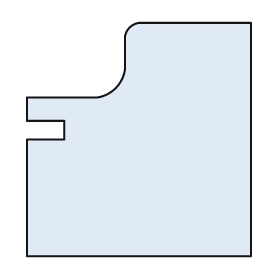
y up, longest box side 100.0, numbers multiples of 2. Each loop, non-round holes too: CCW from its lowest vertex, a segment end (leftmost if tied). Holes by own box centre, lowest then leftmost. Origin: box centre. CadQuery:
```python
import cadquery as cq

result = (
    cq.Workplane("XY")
    .moveTo(-48.0, -50.0)
    .lineTo(48.0, -50.0)
    .lineTo(48.0, 50.0)
    .lineTo(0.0, 50.0)
    .threePointArc((-4.0, 48.0), (-6.0, 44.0))
    .lineTo(-6.0, 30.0)
    .threePointArc((-10.0, 22.0), (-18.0, 18.0))
    .lineTo(-48.0, 18.0)
    .lineTo(-48.0, 8.0)
    .lineTo(-32.0, 8.0)
    .lineTo(-32.0, 0.0)
    .lineTo(-48.0, 0.0)
    .close()
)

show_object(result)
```